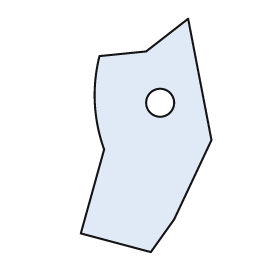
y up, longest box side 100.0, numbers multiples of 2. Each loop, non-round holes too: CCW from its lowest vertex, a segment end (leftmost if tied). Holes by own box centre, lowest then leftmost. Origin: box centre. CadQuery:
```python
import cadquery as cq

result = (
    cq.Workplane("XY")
    .moveTo(2.0, -50.0)
    .lineTo(12.0, -36.0)
    .lineTo(28.0, -2.0)
    .lineTo(18.0, 50.0)
    .lineTo(0.0, 36.0)
    .lineTo(-20.0, 34.0)
    .threePointArc((-22.0, 14.0), (-18.0, -6.0))
    .lineTo(-28.0, -42.0)
    .close()
    .moveTo(6.0, 14.0)
    .circle(6.0)
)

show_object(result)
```